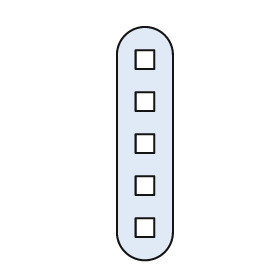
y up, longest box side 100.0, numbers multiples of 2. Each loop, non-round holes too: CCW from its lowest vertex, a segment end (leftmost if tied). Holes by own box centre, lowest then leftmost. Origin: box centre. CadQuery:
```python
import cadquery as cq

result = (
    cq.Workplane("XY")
    .moveTo(-12.0, -38.0)
    .threePointArc((0.0, -50.0), (12.0, -38.0))
    .lineTo(12.0, 38.0)
    .threePointArc((0.0, 50.0), (-12.0, 38.0))
    .close()
    .moveTo(-4.0, -40.0)
    .lineTo(4.0, -40.0)
    .lineTo(4.0, -32.0)
    .lineTo(-4.0, -32.0)
    .close()
    .moveTo(-4.0, -22.0)
    .lineTo(4.0, -22.0)
    .lineTo(4.0, -14.0)
    .lineTo(-4.0, -14.0)
    .close()
    .moveTo(-4.0, -4.0)
    .lineTo(4.0, -4.0)
    .lineTo(4.0, 4.0)
    .lineTo(-4.0, 4.0)
    .close()
    .moveTo(-4.0, 14.0)
    .lineTo(4.0, 14.0)
    .lineTo(4.0, 22.0)
    .lineTo(-4.0, 22.0)
    .close()
    .moveTo(-4.0, 32.0)
    .lineTo(4.0, 32.0)
    .lineTo(4.0, 40.0)
    .lineTo(-4.0, 40.0)
    .close()
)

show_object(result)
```